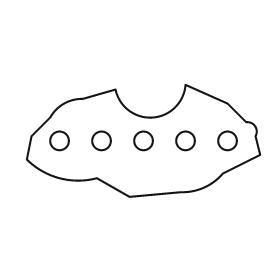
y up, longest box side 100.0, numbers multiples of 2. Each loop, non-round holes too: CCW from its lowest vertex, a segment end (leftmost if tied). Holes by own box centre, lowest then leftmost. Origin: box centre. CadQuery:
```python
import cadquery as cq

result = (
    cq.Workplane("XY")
    .moveTo(-6.0, -24.0)
    .lineTo(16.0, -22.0)
    .threePointArc((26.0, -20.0), (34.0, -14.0))
    .lineTo(50.0, -6.0)
    .lineTo(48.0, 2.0)
    .threePointArc((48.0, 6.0), (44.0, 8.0))
    .lineTo(36.0, 16.0)
    .lineTo(18.0, 24.0)
    .threePointArc((4.0, 10.0), (-12.0, 22.0))
    .lineTo(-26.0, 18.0)
    .threePointArc((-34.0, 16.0), (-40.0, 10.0))
    .lineTo(-48.0, 2.0)
    .lineTo(-50.0, -8.0)
    .threePointArc((-36.0, -16.0), (-20.0, -16.0))
    .close()
    .moveTo(-36.0, 0.0)
    .circle(4.0)
    .moveTo(-18.0, 0.0)
    .circle(4.0)
    .moveTo(0.0, 0.0)
    .circle(4.0)
    .moveTo(18.0, 0.0)
    .circle(4.0)
    .moveTo(36.0, 0.0)
    .circle(4.0)
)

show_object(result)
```